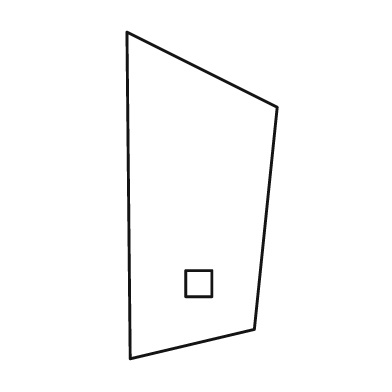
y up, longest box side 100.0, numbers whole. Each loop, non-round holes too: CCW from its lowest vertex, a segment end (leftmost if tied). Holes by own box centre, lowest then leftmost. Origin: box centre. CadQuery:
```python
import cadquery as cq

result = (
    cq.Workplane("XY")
    .moveTo(-22.0, -50.0)
    .lineTo(16.0, -41.0)
    .lineTo(23.0, 27.0)
    .lineTo(-23.0, 50.0)
    .close()
    .moveTo(-5.0, -31.0)
    .lineTo(3.0, -31.0)
    .lineTo(3.0, -23.0)
    .lineTo(-5.0, -23.0)
    .close()
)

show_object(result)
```